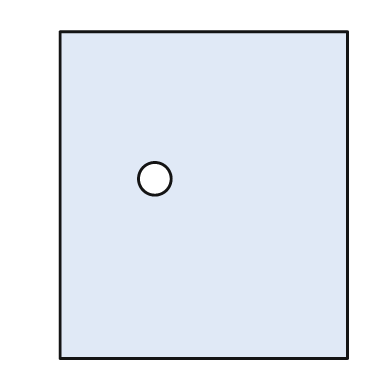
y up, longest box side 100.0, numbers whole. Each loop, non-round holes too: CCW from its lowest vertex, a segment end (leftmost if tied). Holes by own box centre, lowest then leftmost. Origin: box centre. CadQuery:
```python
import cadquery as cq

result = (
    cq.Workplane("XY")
    .moveTo(-44.0, -50.0)
    .lineTo(44.0, -50.0)
    .lineTo(44.0, 50.0)
    .lineTo(-44.0, 50.0)
    .close()
    .moveTo(-15.0, 5.0)
    .circle(5.0)
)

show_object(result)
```